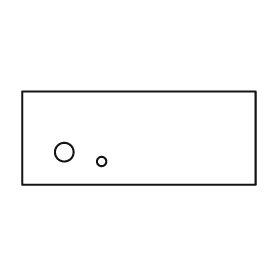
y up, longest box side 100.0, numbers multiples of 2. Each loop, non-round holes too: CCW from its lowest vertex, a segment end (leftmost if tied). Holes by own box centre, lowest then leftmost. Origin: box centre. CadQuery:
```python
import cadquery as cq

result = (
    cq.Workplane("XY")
    .moveTo(-50.0, -20.0)
    .lineTo(50.0, -20.0)
    .lineTo(50.0, 20.0)
    .lineTo(-50.0, 20.0)
    .close()
    .moveTo(-16.0, -10.0)
    .circle(2.0)
    .moveTo(-32.0, -6.0)
    .circle(4.0)
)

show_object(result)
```